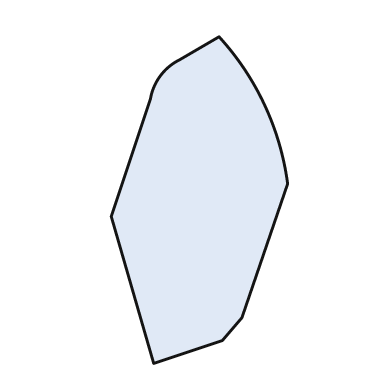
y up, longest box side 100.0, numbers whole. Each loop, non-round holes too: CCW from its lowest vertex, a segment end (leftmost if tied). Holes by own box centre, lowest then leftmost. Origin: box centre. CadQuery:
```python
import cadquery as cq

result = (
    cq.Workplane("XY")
    .moveTo(-14.0, -50.0)
    .lineTo(7.0, -43.0)
    .lineTo(13.0, -36.0)
    .lineTo(27.0, 5.0)
    .threePointArc((20.0, 29.0), (6.0, 50.0))
    .lineTo(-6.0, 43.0)
    .threePointArc((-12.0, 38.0), (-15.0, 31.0))
    .lineTo(-27.0, -5.0)
    .close()
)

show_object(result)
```